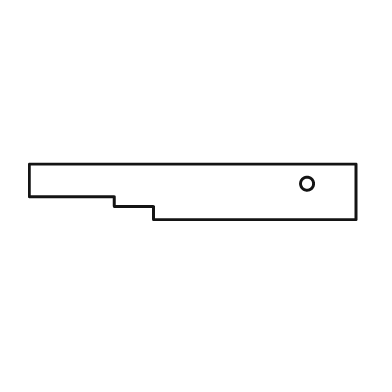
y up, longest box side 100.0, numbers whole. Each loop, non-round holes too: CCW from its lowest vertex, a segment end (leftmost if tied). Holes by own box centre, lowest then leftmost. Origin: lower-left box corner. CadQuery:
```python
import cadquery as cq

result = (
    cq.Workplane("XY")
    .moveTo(38.0, 0.0)
    .lineTo(100.0, 0.0)
    .lineTo(100.0, 17.0)
    .lineTo(0.0, 17.0)
    .lineTo(0.0, 7.0)
    .lineTo(26.0, 7.0)
    .lineTo(26.0, 4.0)
    .lineTo(38.0, 4.0)
    .close()
    .moveTo(85.0, 11.0)
    .circle(2.0)
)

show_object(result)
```